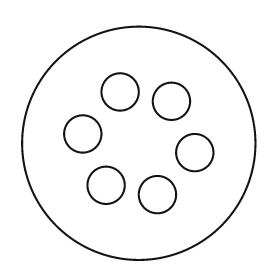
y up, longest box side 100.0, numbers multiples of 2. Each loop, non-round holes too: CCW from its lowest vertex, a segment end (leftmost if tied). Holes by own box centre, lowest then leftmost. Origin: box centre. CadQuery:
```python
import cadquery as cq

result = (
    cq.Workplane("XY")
    .moveTo(0.0, 0.0)
    .circle(50.0)
    .moveTo(8.0, -22.0)
    .circle(8.0)
    .moveTo(-14.0, -18.0)
    .circle(8.0)
    .moveTo(24.0, -4.0)
    .circle(8.0)
    .moveTo(-24.0, 4.0)
    .circle(8.0)
    .moveTo(14.0, 18.0)
    .circle(8.0)
    .moveTo(-8.0, 22.0)
    .circle(8.0)
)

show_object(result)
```